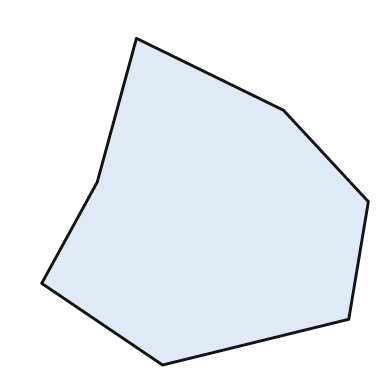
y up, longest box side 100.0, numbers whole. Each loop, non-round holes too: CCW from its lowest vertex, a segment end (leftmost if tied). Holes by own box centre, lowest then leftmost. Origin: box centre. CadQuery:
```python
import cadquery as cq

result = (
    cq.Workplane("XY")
    .moveTo(-13.0, -50.0)
    .lineTo(44.0, -36.0)
    .lineTo(50.0, 0.0)
    .lineTo(24.0, 28.0)
    .lineTo(-21.0, 50.0)
    .lineTo(-33.0, 6.0)
    .lineTo(-50.0, -25.0)
    .close()
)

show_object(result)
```